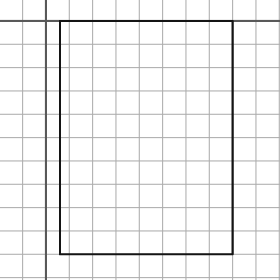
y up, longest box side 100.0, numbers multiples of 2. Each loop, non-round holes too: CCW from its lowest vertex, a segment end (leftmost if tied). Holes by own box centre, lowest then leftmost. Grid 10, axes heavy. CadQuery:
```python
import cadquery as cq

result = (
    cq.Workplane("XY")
    .moveTo(6.0, -100.0)
    .lineTo(80.0, -100.0)
    .lineTo(80.0, 0.0)
    .lineTo(6.0, 0.0)
    .close()
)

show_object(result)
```